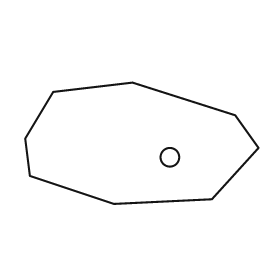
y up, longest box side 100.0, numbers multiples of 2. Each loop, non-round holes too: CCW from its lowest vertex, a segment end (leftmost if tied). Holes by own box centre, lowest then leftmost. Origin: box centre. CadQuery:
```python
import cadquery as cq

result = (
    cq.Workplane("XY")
    .moveTo(-12.0, -26.0)
    .lineTo(30.0, -24.0)
    .lineTo(50.0, -2.0)
    .lineTo(40.0, 12.0)
    .lineTo(-4.0, 26.0)
    .lineTo(-38.0, 22.0)
    .lineTo(-50.0, 2.0)
    .lineTo(-48.0, -14.0)
    .close()
    .moveTo(12.0, -6.0)
    .circle(4.0)
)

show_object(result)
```